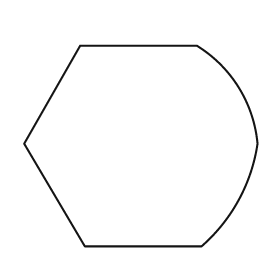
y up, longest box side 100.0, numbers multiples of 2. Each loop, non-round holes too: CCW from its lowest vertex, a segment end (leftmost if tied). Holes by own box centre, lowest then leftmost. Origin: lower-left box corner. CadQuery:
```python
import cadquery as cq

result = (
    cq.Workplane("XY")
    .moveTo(26.0, 0.0)
    .lineTo(76.0, 0.0)
    .threePointArc((92.0, 20.0), (100.0, 44.0))
    .threePointArc((92.0, 68.0), (74.0, 86.0))
    .lineTo(24.0, 86.0)
    .lineTo(0.0, 44.0)
    .close()
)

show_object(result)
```